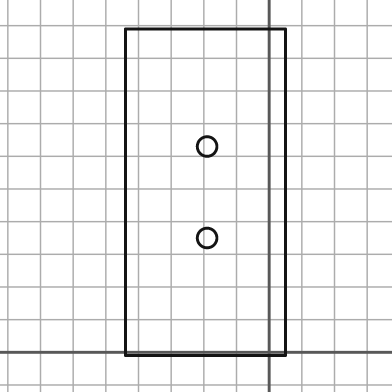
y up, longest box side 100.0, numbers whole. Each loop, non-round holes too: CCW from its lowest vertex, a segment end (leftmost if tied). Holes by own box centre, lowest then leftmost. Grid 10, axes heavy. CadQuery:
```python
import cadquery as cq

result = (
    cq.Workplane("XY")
    .moveTo(-44.0, -1.0)
    .lineTo(5.0, -1.0)
    .lineTo(5.0, 99.0)
    .lineTo(-44.0, 99.0)
    .close()
    .moveTo(-19.0, 35.0)
    .circle(3.0)
    .moveTo(-19.0, 63.0)
    .circle(3.0)
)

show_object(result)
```